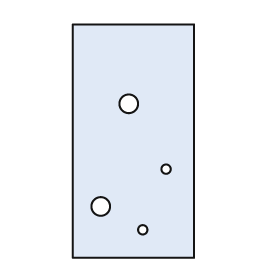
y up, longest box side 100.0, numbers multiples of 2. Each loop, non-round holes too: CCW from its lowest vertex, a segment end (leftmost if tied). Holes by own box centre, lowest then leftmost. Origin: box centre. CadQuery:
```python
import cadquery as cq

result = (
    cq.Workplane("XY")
    .moveTo(-26.0, -50.0)
    .lineTo(26.0, -50.0)
    .lineTo(26.0, 50.0)
    .lineTo(-26.0, 50.0)
    .close()
    .moveTo(4.0, -38.0)
    .circle(2.0)
    .moveTo(-14.0, -28.0)
    .circle(4.0)
    .moveTo(14.0, -12.0)
    .circle(2.0)
    .moveTo(-2.0, 16.0)
    .circle(4.0)
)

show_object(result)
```